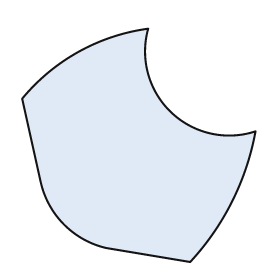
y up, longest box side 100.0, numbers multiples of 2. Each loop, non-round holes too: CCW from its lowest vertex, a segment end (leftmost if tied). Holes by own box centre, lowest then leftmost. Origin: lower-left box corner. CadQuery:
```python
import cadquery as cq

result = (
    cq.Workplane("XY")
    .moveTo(72.0, 0.0)
    .threePointArc((90.0, 26.0), (100.0, 56.0))
    .threePointArc((64.0, 64.0), (54.0, 100.0))
    .threePointArc((24.0, 90.0), (0.0, 70.0))
    .lineTo(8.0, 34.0)
    .threePointArc((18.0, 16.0), (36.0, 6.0))
    .close()
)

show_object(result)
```